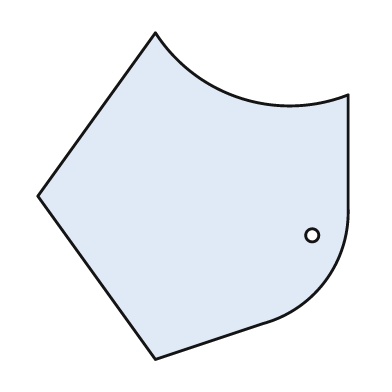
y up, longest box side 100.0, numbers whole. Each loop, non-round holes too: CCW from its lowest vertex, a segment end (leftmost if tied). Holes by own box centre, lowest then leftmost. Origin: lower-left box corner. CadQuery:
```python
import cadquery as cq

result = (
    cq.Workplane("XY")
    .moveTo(36.0, 0.0)
    .lineTo(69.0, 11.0)
    .threePointArc((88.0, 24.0), (95.0, 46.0))
    .lineTo(95.0, 81.0)
    .threePointArc((62.0, 80.0), (36.0, 100.0))
    .lineTo(0.0, 50.0)
    .close()
    .moveTo(84.0, 38.0)
    .circle(2.0)
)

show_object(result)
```